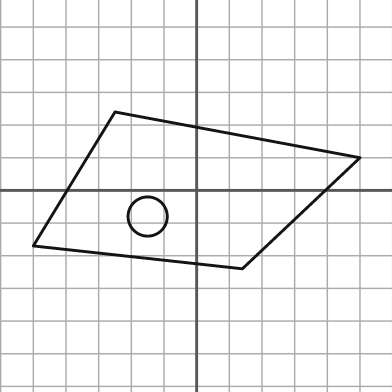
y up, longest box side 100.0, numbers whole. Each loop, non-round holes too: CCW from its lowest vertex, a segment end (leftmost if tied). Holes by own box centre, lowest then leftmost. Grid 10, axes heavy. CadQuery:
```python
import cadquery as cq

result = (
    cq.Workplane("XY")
    .moveTo(14.0, -24.0)
    .lineTo(50.0, 10.0)
    .lineTo(-25.0, 24.0)
    .lineTo(-50.0, -17.0)
    .close()
    .moveTo(-15.0, -8.0)
    .circle(6.0)
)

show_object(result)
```